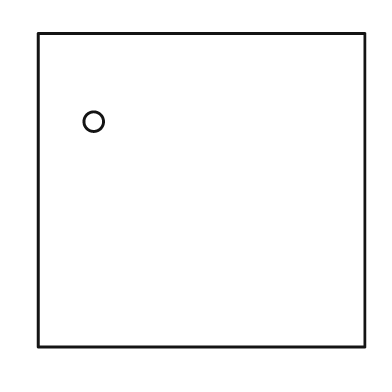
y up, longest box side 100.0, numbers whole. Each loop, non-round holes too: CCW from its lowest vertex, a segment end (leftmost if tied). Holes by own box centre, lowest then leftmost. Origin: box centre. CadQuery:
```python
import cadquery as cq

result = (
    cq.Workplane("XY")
    .moveTo(-50.0, -48.0)
    .lineTo(50.0, -48.0)
    .lineTo(50.0, 48.0)
    .lineTo(-50.0, 48.0)
    .close()
    .moveTo(-33.0, 21.0)
    .circle(3.0)
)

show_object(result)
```